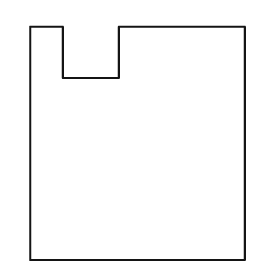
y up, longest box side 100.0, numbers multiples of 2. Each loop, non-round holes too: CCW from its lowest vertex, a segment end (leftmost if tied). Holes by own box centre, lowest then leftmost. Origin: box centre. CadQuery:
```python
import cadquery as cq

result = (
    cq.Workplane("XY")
    .moveTo(-46.0, -50.0)
    .lineTo(46.0, -50.0)
    .lineTo(46.0, 50.0)
    .lineTo(-8.0, 50.0)
    .lineTo(-8.0, 28.0)
    .lineTo(-32.0, 28.0)
    .lineTo(-32.0, 50.0)
    .lineTo(-46.0, 50.0)
    .close()
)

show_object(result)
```